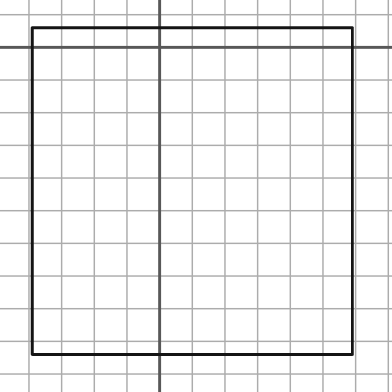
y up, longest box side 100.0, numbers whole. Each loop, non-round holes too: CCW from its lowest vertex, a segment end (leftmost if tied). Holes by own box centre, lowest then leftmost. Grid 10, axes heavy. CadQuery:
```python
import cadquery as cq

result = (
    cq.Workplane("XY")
    .moveTo(-39.0, -94.0)
    .lineTo(59.0, -94.0)
    .lineTo(59.0, 6.0)
    .lineTo(-39.0, 6.0)
    .close()
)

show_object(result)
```